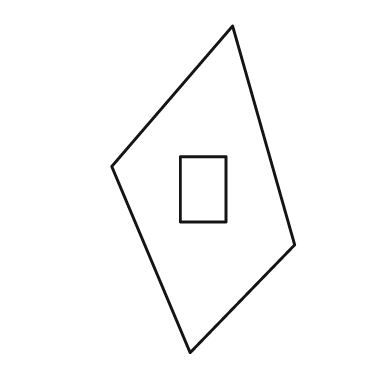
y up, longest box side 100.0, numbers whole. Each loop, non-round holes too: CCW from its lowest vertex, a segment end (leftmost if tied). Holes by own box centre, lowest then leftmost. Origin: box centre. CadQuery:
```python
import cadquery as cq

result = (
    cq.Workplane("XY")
    .moveTo(-4.0, -50.0)
    .lineTo(28.0, -17.0)
    .lineTo(9.0, 50.0)
    .lineTo(-28.0, 7.0)
    .close()
    .moveTo(-7.0, -10.0)
    .lineTo(7.0, -10.0)
    .lineTo(7.0, 10.0)
    .lineTo(-7.0, 10.0)
    .close()
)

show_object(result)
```